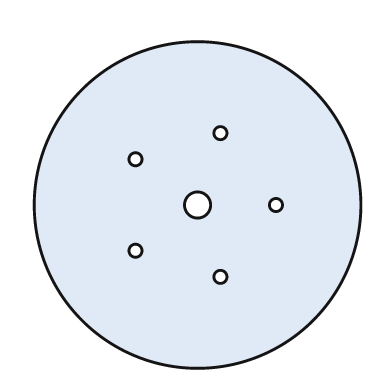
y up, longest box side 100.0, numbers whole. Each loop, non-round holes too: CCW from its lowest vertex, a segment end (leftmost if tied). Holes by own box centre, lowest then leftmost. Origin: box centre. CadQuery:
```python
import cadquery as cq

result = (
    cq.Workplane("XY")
    .moveTo(0.0, 0.0)
    .circle(50.0)
    .moveTo(7.0, -22.0)
    .circle(2.0)
    .moveTo(-19.0, -14.0)
    .circle(2.0)
    .moveTo(0.0, 0.0)
    .circle(4.0)
    .moveTo(24.0, 0.0)
    .circle(2.0)
    .moveTo(-19.0, 14.0)
    .circle(2.0)
    .moveTo(7.0, 22.0)
    .circle(2.0)
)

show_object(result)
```